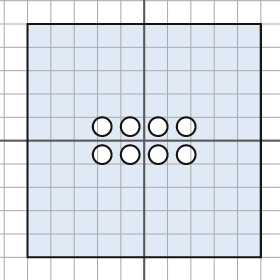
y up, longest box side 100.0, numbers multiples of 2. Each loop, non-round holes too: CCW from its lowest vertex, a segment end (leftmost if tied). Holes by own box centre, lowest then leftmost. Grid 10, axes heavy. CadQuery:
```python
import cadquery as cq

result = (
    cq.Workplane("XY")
    .moveTo(-50.0, -50.0)
    .lineTo(50.0, -50.0)
    .lineTo(50.0, 50.0)
    .lineTo(-50.0, 50.0)
    .close()
    .moveTo(-18.0, -6.0)
    .circle(4.0)
    .moveTo(-6.0, -6.0)
    .circle(4.0)
    .moveTo(6.0, -6.0)
    .circle(4.0)
    .moveTo(18.0, -6.0)
    .circle(4.0)
    .moveTo(-18.0, 6.0)
    .circle(4.0)
    .moveTo(-6.0, 6.0)
    .circle(4.0)
    .moveTo(6.0, 6.0)
    .circle(4.0)
    .moveTo(18.0, 6.0)
    .circle(4.0)
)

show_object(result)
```